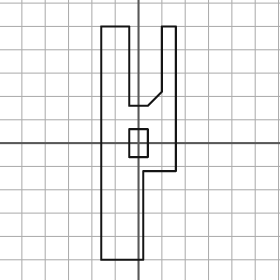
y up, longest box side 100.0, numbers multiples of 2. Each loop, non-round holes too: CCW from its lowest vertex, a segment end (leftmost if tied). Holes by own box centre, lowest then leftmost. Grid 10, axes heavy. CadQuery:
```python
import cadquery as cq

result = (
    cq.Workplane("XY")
    .moveTo(-16.0, -50.0)
    .lineTo(2.0, -50.0)
    .lineTo(2.0, -12.0)
    .lineTo(16.0, -12.0)
    .lineTo(16.0, 50.0)
    .lineTo(10.0, 50.0)
    .lineTo(10.0, 22.0)
    .lineTo(4.0, 16.0)
    .lineTo(-4.0, 16.0)
    .lineTo(-4.0, 50.0)
    .lineTo(-16.0, 50.0)
    .close()
    .moveTo(-4.0, -6.0)
    .lineTo(4.0, -6.0)
    .lineTo(4.0, 6.0)
    .lineTo(-4.0, 6.0)
    .close()
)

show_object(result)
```